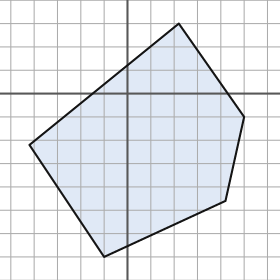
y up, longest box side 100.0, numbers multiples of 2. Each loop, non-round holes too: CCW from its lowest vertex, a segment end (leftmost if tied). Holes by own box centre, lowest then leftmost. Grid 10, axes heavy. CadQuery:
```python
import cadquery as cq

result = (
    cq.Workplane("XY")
    .moveTo(-10.0, -70.0)
    .lineTo(42.0, -46.0)
    .lineTo(50.0, -10.0)
    .lineTo(22.0, 30.0)
    .lineTo(-42.0, -22.0)
    .close()
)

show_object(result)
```